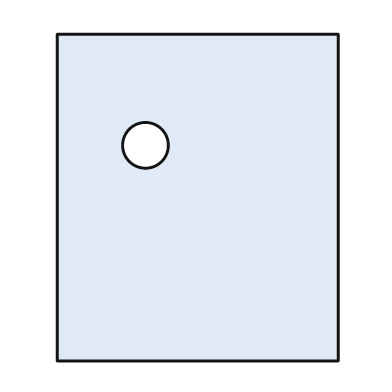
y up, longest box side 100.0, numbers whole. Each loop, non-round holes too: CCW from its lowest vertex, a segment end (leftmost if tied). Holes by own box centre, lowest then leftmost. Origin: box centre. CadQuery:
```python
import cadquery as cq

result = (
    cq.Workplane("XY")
    .moveTo(-43.0, -50.0)
    .lineTo(43.0, -50.0)
    .lineTo(43.0, 50.0)
    .lineTo(-43.0, 50.0)
    .close()
    .moveTo(-16.0, 16.0)
    .circle(7.0)
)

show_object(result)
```